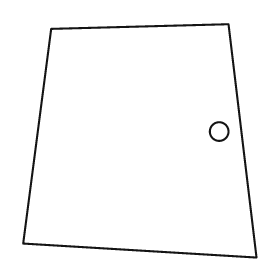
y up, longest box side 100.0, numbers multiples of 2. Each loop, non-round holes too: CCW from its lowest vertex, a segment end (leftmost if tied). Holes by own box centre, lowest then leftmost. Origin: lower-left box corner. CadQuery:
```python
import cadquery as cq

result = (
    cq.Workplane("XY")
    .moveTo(100.0, 0.0)
    .lineTo(88.0, 100.0)
    .lineTo(12.0, 98.0)
    .lineTo(0.0, 6.0)
    .close()
    .moveTo(84.0, 54.0)
    .circle(4.0)
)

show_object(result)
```